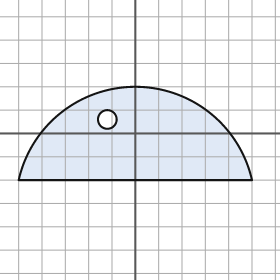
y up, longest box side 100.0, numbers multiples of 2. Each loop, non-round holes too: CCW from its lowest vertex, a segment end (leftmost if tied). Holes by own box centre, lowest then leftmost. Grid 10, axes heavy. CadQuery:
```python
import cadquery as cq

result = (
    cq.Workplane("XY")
    .moveTo(-50.0, -20.0)
    .lineTo(50.0, -20.0)
    .threePointArc((0.0, 20.0), (-50.0, -20.0))
    .close()
    .moveTo(-12.0, 6.0)
    .circle(4.0)
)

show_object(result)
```